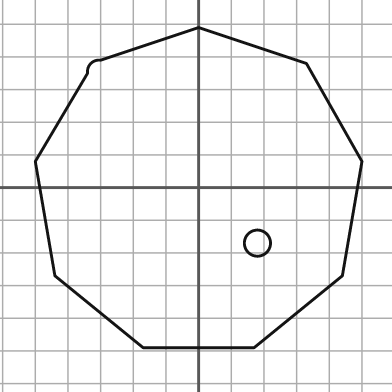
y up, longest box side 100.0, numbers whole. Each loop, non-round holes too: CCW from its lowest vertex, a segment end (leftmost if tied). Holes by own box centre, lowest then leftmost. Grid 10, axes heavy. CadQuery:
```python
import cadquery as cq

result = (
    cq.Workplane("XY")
    .moveTo(-17.0, -49.0)
    .lineTo(17.0, -49.0)
    .lineTo(44.0, -27.0)
    .lineTo(50.0, 8.0)
    .lineTo(33.0, 38.0)
    .lineTo(0.0, 49.0)
    .lineTo(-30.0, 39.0)
    .threePointArc((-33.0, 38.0), (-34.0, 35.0))
    .lineTo(-50.0, 8.0)
    .lineTo(-44.0, -27.0)
    .close()
    .moveTo(18.0, -17.0)
    .circle(4.0)
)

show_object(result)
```